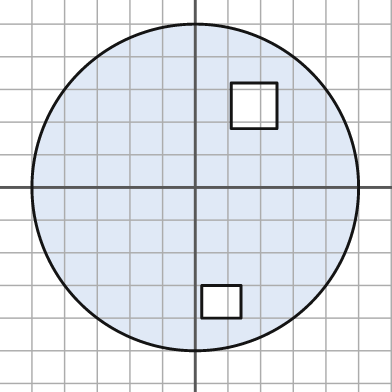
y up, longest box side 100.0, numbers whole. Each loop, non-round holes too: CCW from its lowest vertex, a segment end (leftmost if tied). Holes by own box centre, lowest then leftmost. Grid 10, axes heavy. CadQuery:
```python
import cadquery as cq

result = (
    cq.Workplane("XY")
    .moveTo(0.0, 0.0)
    .circle(50.0)
    .moveTo(2.0, -40.0)
    .lineTo(14.0, -40.0)
    .lineTo(14.0, -30.0)
    .lineTo(2.0, -30.0)
    .close()
    .moveTo(11.0, 18.0)
    .lineTo(25.0, 18.0)
    .lineTo(25.0, 32.0)
    .lineTo(11.0, 32.0)
    .close()
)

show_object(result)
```